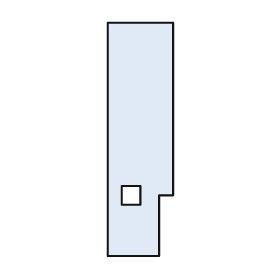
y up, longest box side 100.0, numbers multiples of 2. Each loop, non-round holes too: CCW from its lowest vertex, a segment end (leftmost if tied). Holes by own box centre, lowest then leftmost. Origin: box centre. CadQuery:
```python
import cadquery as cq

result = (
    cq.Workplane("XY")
    .moveTo(-14.0, -50.0)
    .lineTo(8.0, -50.0)
    .lineTo(8.0, -24.0)
    .lineTo(14.0, -24.0)
    .lineTo(14.0, 50.0)
    .lineTo(-14.0, 50.0)
    .close()
    .moveTo(-8.0, -28.0)
    .lineTo(0.0, -28.0)
    .lineTo(0.0, -20.0)
    .lineTo(-8.0, -20.0)
    .close()
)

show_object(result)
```